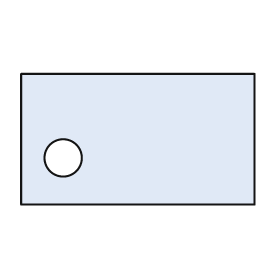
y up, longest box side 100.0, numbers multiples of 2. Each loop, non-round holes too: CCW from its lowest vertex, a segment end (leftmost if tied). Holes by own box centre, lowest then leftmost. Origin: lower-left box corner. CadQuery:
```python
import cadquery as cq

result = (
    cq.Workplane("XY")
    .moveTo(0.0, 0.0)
    .lineTo(100.0, 0.0)
    .lineTo(100.0, 56.0)
    .lineTo(0.0, 56.0)
    .close()
    .moveTo(18.0, 20.0)
    .circle(8.0)
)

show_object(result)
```